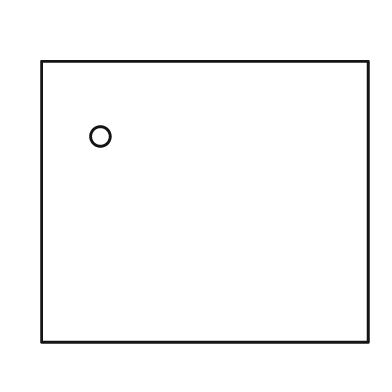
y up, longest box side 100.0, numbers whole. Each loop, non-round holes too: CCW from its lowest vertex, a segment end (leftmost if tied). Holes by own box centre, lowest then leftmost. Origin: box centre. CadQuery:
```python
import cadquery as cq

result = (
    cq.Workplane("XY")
    .moveTo(-50.0, -43.0)
    .lineTo(50.0, -43.0)
    .lineTo(50.0, 43.0)
    .lineTo(-50.0, 43.0)
    .close()
    .moveTo(-32.0, 20.0)
    .circle(3.0)
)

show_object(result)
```